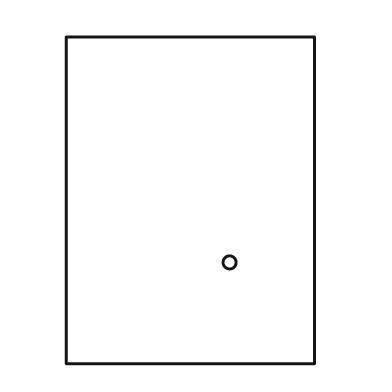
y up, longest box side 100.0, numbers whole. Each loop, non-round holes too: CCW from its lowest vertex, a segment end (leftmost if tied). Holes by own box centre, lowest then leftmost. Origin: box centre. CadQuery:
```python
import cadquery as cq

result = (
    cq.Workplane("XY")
    .moveTo(-38.0, -50.0)
    .lineTo(38.0, -50.0)
    .lineTo(38.0, 50.0)
    .lineTo(-38.0, 50.0)
    .close()
    .moveTo(12.0, -19.0)
    .circle(2.0)
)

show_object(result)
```